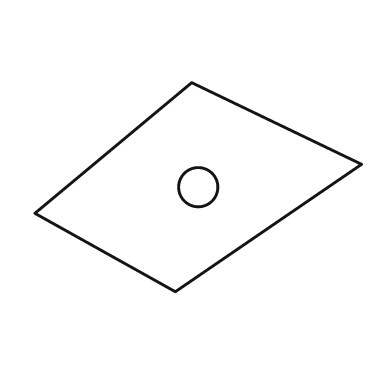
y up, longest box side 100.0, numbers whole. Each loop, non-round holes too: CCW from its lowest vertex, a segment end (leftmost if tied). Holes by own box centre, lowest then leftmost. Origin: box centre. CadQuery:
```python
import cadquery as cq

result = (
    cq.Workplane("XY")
    .moveTo(-7.0, -32.0)
    .lineTo(50.0, 7.0)
    .lineTo(-2.0, 32.0)
    .lineTo(-50.0, -8.0)
    .close()
    .moveTo(0.0, 0.0)
    .circle(6.0)
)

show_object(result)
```